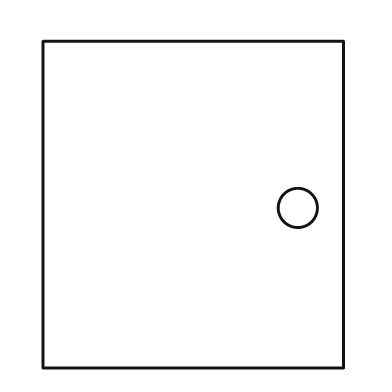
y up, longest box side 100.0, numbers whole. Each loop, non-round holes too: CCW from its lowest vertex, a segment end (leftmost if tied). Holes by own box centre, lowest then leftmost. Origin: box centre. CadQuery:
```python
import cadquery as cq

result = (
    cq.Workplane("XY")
    .moveTo(-46.0, -50.0)
    .lineTo(46.0, -50.0)
    .lineTo(46.0, 50.0)
    .lineTo(-46.0, 50.0)
    .close()
    .moveTo(32.0, -1.0)
    .circle(6.0)
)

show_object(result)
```